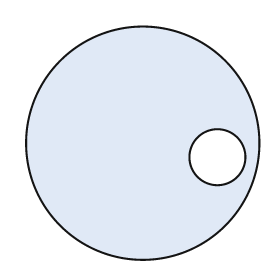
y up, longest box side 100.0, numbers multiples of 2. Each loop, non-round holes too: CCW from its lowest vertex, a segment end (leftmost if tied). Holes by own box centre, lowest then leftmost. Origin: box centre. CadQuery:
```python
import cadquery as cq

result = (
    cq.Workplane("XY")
    .moveTo(0.0, 0.0)
    .circle(50.0)
    .moveTo(32.0, -6.0)
    .circle(12.0)
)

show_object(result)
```